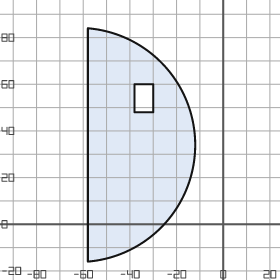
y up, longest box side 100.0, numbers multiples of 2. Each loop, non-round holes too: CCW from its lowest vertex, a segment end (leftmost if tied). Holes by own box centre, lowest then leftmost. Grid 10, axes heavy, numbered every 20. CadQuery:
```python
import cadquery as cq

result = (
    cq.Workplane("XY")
    .moveTo(-58.0, -16.0)
    .threePointArc((-12.0, 34.0), (-58.0, 84.0))
    .close()
    .moveTo(-38.0, 48.0)
    .lineTo(-30.0, 48.0)
    .lineTo(-30.0, 60.0)
    .lineTo(-38.0, 60.0)
    .close()
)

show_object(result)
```